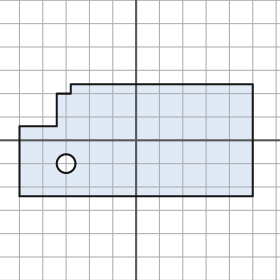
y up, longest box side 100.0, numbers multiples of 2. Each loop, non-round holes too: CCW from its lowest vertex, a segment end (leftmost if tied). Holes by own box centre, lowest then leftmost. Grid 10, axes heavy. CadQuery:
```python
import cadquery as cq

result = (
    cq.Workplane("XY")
    .moveTo(-50.0, -24.0)
    .lineTo(50.0, -24.0)
    .lineTo(50.0, 24.0)
    .lineTo(-28.0, 24.0)
    .lineTo(-28.0, 20.0)
    .lineTo(-34.0, 20.0)
    .lineTo(-34.0, 6.0)
    .lineTo(-50.0, 6.0)
    .close()
    .moveTo(-30.0, -10.0)
    .circle(4.0)
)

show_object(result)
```